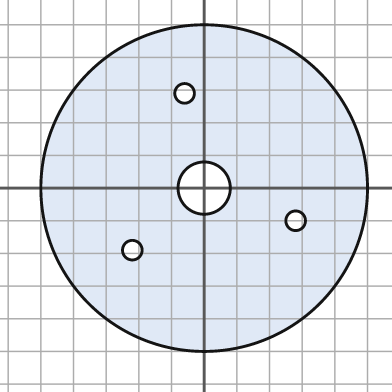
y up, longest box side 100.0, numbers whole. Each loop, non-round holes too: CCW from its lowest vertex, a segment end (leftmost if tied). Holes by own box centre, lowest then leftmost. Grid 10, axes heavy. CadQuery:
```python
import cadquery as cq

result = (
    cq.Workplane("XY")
    .moveTo(0.0, 0.0)
    .circle(50.0)
    .moveTo(-22.0, -19.0)
    .circle(3.0)
    .moveTo(28.0, -10.0)
    .circle(3.0)
    .moveTo(0.0, 0.0)
    .circle(8.0)
    .moveTo(-6.0, 29.0)
    .circle(3.0)
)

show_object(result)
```